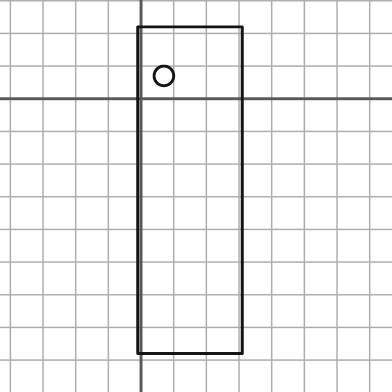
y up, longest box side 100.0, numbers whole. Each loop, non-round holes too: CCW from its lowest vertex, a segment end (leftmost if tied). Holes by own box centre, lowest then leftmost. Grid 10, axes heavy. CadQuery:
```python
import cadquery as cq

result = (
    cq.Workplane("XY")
    .moveTo(-1.0, -78.0)
    .lineTo(31.0, -78.0)
    .lineTo(31.0, 22.0)
    .lineTo(-1.0, 22.0)
    .close()
    .moveTo(7.0, 7.0)
    .circle(3.0)
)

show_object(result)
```